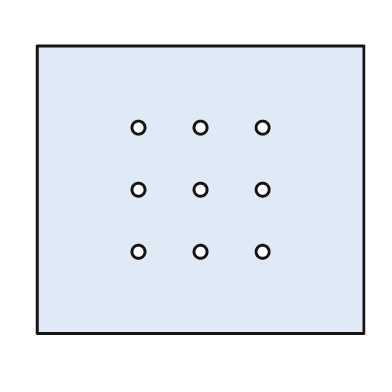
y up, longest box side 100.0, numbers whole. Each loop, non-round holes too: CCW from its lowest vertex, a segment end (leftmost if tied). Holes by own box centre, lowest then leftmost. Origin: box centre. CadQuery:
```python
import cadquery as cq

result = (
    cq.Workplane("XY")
    .moveTo(-50.0, -44.0)
    .lineTo(50.0, -44.0)
    .lineTo(50.0, 44.0)
    .lineTo(-50.0, 44.0)
    .close()
    .moveTo(-19.0, -19.0)
    .circle(2.0)
    .moveTo(0.0, -19.0)
    .circle(2.0)
    .moveTo(19.0, -19.0)
    .circle(2.0)
    .moveTo(-19.0, 0.0)
    .circle(2.0)
    .moveTo(0.0, 0.0)
    .circle(2.0)
    .moveTo(19.0, 0.0)
    .circle(2.0)
    .moveTo(-19.0, 19.0)
    .circle(2.0)
    .moveTo(0.0, 19.0)
    .circle(2.0)
    .moveTo(19.0, 19.0)
    .circle(2.0)
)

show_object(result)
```